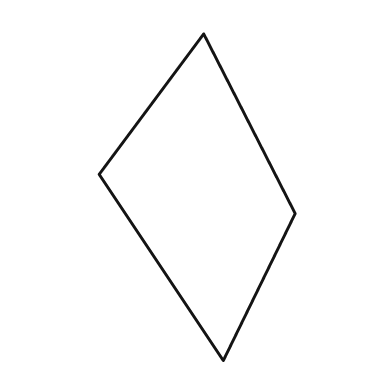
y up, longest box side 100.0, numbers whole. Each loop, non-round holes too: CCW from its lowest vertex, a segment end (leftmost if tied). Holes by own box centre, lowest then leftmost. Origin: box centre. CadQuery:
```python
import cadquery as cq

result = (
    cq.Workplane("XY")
    .moveTo(8.0, -50.0)
    .lineTo(30.0, -5.0)
    .lineTo(2.0, 50.0)
    .lineTo(-30.0, 7.0)
    .close()
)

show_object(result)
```